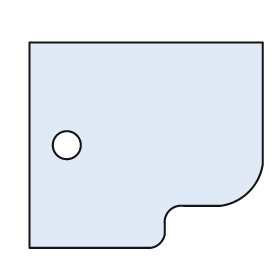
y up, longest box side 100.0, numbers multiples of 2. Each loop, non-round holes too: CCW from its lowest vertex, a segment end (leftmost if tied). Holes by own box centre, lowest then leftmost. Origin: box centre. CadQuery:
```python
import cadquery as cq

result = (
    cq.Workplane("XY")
    .moveTo(-50.0, -44.0)
    .lineTo(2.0, -44.0)
    .threePointArc((6.0, -42.0), (8.0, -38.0))
    .lineTo(8.0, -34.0)
    .threePointArc((10.0, -28.0), (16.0, -26.0))
    .lineTo(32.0, -26.0)
    .threePointArc((44.0, -20.0), (50.0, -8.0))
    .lineTo(50.0, 44.0)
    .lineTo(-50.0, 44.0)
    .close()
    .moveTo(-34.0, 0.0)
    .circle(6.0)
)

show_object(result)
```